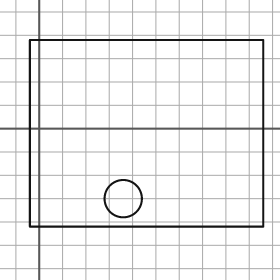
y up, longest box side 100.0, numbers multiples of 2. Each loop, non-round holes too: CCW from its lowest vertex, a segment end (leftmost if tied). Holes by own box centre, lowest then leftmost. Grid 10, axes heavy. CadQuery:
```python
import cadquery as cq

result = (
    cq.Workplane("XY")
    .moveTo(-4.0, -42.0)
    .lineTo(96.0, -42.0)
    .lineTo(96.0, 38.0)
    .lineTo(-4.0, 38.0)
    .close()
    .moveTo(36.0, -30.0)
    .circle(8.0)
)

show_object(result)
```